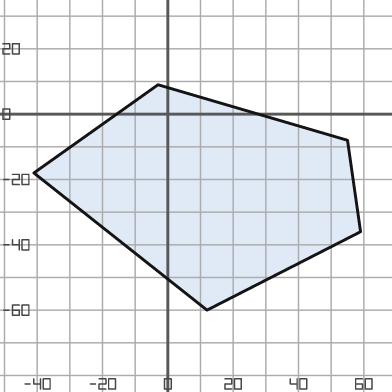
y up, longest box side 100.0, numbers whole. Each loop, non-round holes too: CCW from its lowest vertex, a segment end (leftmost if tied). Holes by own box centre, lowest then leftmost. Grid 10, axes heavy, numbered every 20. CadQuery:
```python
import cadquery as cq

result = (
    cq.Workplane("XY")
    .moveTo(12.0, -60.0)
    .lineTo(59.0, -36.0)
    .lineTo(55.0, -8.0)
    .lineTo(-3.0, 9.0)
    .lineTo(-41.0, -18.0)
    .close()
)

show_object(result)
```